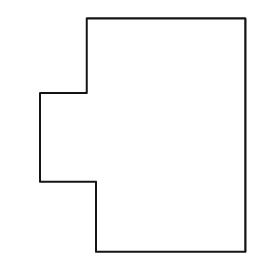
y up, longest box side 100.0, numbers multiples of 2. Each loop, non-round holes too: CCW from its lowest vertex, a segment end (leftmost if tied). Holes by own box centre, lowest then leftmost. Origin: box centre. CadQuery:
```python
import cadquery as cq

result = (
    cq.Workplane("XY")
    .moveTo(-20.0, -50.0)
    .lineTo(44.0, -50.0)
    .lineTo(44.0, 50.0)
    .lineTo(-24.0, 50.0)
    .lineTo(-24.0, 18.0)
    .lineTo(-44.0, 18.0)
    .lineTo(-44.0, -20.0)
    .lineTo(-20.0, -20.0)
    .close()
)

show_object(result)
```